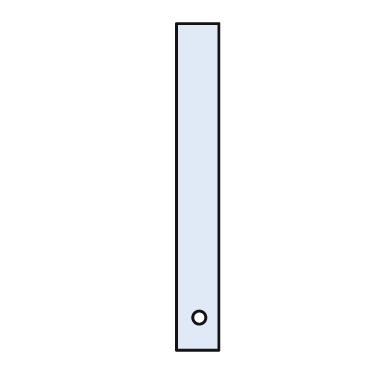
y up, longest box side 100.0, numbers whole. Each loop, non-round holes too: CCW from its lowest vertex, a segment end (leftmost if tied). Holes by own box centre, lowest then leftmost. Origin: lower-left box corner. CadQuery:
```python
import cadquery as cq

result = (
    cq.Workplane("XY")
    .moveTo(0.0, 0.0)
    .lineTo(13.0, 0.0)
    .lineTo(13.0, 100.0)
    .lineTo(0.0, 100.0)
    .close()
    .moveTo(7.0, 10.0)
    .circle(2.0)
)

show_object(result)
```